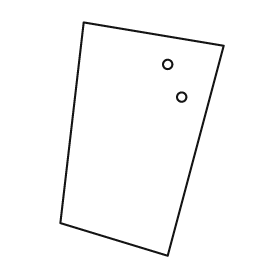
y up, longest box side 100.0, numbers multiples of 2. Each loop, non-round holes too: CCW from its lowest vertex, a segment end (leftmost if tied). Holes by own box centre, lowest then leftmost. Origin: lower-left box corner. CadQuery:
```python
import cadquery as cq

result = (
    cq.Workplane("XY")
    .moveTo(46.0, 0.0)
    .lineTo(70.0, 90.0)
    .lineTo(10.0, 100.0)
    .lineTo(0.0, 14.0)
    .close()
    .moveTo(52.0, 68.0)
    .circle(2.0)
    .moveTo(46.0, 82.0)
    .circle(2.0)
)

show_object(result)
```